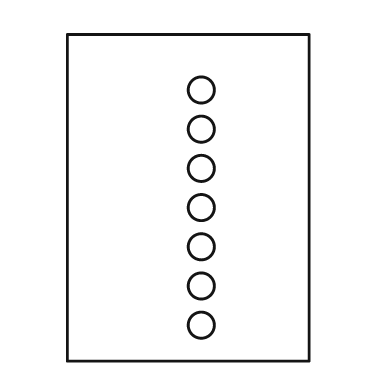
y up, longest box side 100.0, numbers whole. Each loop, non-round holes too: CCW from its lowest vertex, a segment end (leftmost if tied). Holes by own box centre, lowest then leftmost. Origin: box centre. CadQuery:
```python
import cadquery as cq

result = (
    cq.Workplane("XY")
    .moveTo(-37.0, -50.0)
    .lineTo(37.0, -50.0)
    .lineTo(37.0, 50.0)
    .lineTo(-37.0, 50.0)
    .close()
    .moveTo(4.0, -39.0)
    .circle(4.0)
    .moveTo(4.0, -27.0)
    .circle(4.0)
    .moveTo(4.0, -15.0)
    .circle(4.0)
    .moveTo(4.0, -3.0)
    .circle(4.0)
    .moveTo(4.0, 9.0)
    .circle(4.0)
    .moveTo(4.0, 21.0)
    .circle(4.0)
    .moveTo(4.0, 33.0)
    .circle(4.0)
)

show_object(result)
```